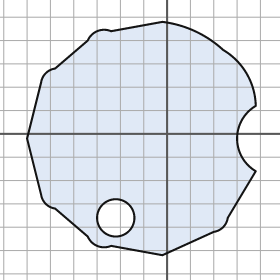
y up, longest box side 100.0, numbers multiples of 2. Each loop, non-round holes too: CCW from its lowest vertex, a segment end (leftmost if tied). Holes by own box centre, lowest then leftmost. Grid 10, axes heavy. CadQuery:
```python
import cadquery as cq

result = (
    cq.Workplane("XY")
    .moveTo(-2.0, -52.0)
    .lineTo(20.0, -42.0)
    .threePointArc((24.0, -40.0), (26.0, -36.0))
    .lineTo(38.0, -16.0)
    .threePointArc((30.0, -2.0), (38.0, 12.0))
    .threePointArc((34.0, 26.0), (24.0, 36.0))
    .threePointArc((12.0, 44.0), (-2.0, 48.0))
    .lineTo(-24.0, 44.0)
    .threePointArc((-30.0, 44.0), (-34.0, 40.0))
    .lineTo(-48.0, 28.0)
    .threePointArc((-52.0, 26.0), (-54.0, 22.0))
    .lineTo(-60.0, -2.0)
    .lineTo(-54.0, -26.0)
    .threePointArc((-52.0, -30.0), (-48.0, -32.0))
    .lineTo(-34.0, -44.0)
    .threePointArc((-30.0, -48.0), (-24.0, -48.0))
    .close()
    .moveTo(-22.0, -36.0)
    .circle(8.0)
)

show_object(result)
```